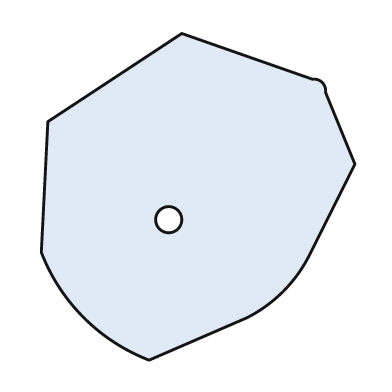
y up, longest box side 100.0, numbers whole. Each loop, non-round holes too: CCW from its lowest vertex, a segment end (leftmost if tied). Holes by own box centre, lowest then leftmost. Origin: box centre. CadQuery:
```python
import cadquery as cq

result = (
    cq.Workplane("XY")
    .moveTo(-15.0, -50.0)
    .lineTo(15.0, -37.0)
    .threePointArc((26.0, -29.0), (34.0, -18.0))
    .lineTo(48.0, 10.0)
    .lineTo(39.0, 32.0)
    .threePointArc((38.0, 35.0), (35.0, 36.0))
    .lineTo(-5.0, 50.0)
    .lineTo(-46.0, 23.0)
    .lineTo(-48.0, -17.0)
    .threePointArc((-35.0, -37.0), (-15.0, -50.0))
    .close()
    .moveTo(-9.0, -7.0)
    .circle(4.0)
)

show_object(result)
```